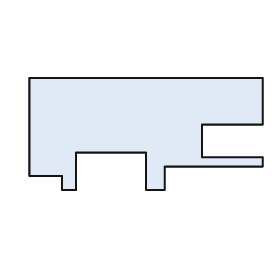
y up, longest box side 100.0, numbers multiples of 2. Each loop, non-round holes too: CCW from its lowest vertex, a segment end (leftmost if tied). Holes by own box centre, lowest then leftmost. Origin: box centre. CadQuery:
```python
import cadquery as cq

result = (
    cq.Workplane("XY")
    .moveTo(-36.0, -24.0)
    .lineTo(-30.0, -24.0)
    .lineTo(-30.0, -8.0)
    .lineTo(0.0, -8.0)
    .lineTo(0.0, -24.0)
    .lineTo(8.0, -24.0)
    .lineTo(8.0, -14.0)
    .lineTo(50.0, -14.0)
    .lineTo(50.0, -10.0)
    .lineTo(24.0, -10.0)
    .lineTo(24.0, 4.0)
    .lineTo(50.0, 4.0)
    .lineTo(50.0, 24.0)
    .lineTo(-50.0, 24.0)
    .lineTo(-50.0, -18.0)
    .lineTo(-36.0, -18.0)
    .close()
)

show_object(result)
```